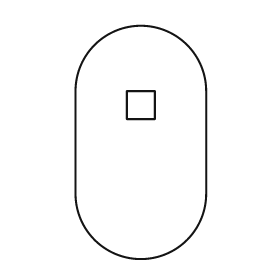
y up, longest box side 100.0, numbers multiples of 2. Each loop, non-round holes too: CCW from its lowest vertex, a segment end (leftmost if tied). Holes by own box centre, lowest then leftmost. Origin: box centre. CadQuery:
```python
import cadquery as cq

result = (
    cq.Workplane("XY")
    .moveTo(-28.0, -22.0)
    .threePointArc((0.0, -50.0), (28.0, -22.0))
    .lineTo(28.0, 22.0)
    .threePointArc((0.0, 50.0), (-28.0, 22.0))
    .close()
    .moveTo(-6.0, 10.0)
    .lineTo(6.0, 10.0)
    .lineTo(6.0, 22.0)
    .lineTo(-6.0, 22.0)
    .close()
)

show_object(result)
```